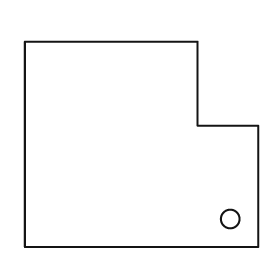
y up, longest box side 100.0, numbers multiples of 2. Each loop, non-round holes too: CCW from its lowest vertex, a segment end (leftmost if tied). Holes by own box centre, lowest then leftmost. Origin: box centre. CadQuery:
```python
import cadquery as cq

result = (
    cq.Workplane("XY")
    .moveTo(-50.0, -44.0)
    .lineTo(50.0, -44.0)
    .lineTo(50.0, 8.0)
    .lineTo(24.0, 8.0)
    .lineTo(24.0, 44.0)
    .lineTo(-50.0, 44.0)
    .close()
    .moveTo(38.0, -32.0)
    .circle(4.0)
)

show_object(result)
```